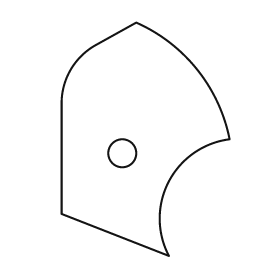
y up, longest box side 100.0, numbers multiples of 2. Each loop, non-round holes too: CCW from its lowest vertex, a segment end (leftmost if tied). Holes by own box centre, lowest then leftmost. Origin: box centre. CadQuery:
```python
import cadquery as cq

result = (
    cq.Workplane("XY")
    .moveTo(10.0, -50.0)
    .threePointArc((10.0, -18.0), (36.0, 0.0))
    .threePointArc((22.0, 30.0), (-4.0, 50.0))
    .lineTo(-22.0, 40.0)
    .threePointArc((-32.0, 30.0), (-36.0, 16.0))
    .lineTo(-36.0, -32.0)
    .close()
    .moveTo(-10.0, -6.0)
    .circle(6.0)
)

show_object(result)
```